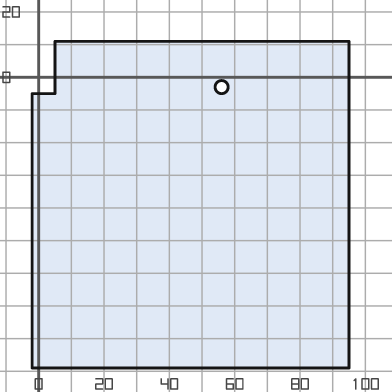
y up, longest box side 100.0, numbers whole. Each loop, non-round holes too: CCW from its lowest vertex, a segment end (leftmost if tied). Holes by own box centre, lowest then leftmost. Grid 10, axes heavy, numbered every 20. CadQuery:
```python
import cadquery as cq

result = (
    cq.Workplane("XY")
    .moveTo(-2.0, -89.0)
    .lineTo(95.0, -89.0)
    .lineTo(95.0, 11.0)
    .lineTo(5.0, 11.0)
    .lineTo(5.0, -5.0)
    .lineTo(-2.0, -5.0)
    .close()
    .moveTo(56.0, -3.0)
    .circle(2.0)
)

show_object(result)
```